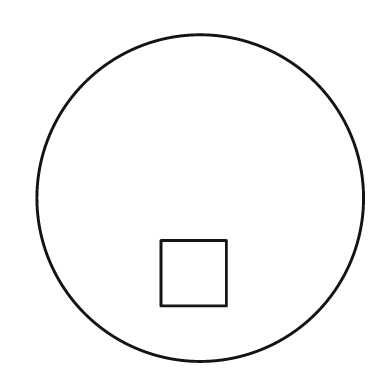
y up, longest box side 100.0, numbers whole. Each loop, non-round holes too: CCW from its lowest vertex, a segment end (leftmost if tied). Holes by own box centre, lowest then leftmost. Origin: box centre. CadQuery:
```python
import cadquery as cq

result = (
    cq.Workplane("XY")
    .moveTo(0.0, 0.0)
    .circle(50.0)
    .moveTo(-12.0, -33.0)
    .lineTo(8.0, -33.0)
    .lineTo(8.0, -13.0)
    .lineTo(-12.0, -13.0)
    .close()
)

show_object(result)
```